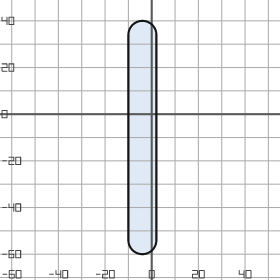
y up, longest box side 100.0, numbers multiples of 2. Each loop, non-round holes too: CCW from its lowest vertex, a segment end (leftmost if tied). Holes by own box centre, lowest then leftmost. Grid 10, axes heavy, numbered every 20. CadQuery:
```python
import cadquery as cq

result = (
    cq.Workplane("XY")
    .moveTo(-10.0, -54.0)
    .threePointArc((-4.0, -60.0), (2.0, -54.0))
    .lineTo(2.0, 34.0)
    .threePointArc((-4.0, 40.0), (-10.0, 34.0))
    .close()
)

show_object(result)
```